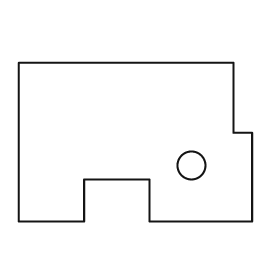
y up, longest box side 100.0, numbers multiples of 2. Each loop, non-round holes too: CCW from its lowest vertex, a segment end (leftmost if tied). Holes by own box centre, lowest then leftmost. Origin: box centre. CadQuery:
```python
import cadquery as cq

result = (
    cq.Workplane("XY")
    .moveTo(-50.0, -34.0)
    .lineTo(-22.0, -34.0)
    .lineTo(-22.0, -16.0)
    .lineTo(6.0, -16.0)
    .lineTo(6.0, -34.0)
    .lineTo(50.0, -34.0)
    .lineTo(50.0, 4.0)
    .lineTo(42.0, 4.0)
    .lineTo(42.0, 34.0)
    .lineTo(-50.0, 34.0)
    .close()
    .moveTo(24.0, -10.0)
    .circle(6.0)
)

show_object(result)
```